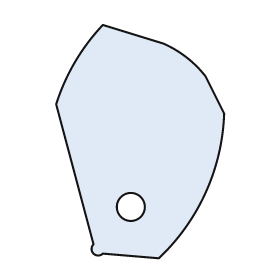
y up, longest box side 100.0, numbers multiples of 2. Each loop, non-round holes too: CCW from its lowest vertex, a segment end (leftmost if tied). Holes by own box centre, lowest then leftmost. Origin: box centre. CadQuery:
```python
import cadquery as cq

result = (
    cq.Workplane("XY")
    .moveTo(8.0, -50.0)
    .threePointArc((28.0, -22.0), (36.0, 12.0))
    .lineTo(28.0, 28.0)
    .threePointArc((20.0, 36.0), (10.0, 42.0))
    .lineTo(-16.0, 50.0)
    .threePointArc((-28.0, 34.0), (-36.0, 16.0))
    .lineTo(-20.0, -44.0)
    .threePointArc((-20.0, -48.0), (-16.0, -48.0))
    .close()
    .moveTo(-4.0, -28.0)
    .circle(6.0)
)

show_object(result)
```